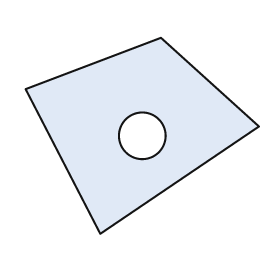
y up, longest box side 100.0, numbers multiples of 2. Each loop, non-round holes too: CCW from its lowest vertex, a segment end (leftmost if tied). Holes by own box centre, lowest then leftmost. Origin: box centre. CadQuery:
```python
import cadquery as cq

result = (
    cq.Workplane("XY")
    .moveTo(-18.0, -42.0)
    .lineTo(50.0, 4.0)
    .lineTo(8.0, 42.0)
    .lineTo(-50.0, 20.0)
    .close()
    .moveTo(0.0, 0.0)
    .circle(10.0)
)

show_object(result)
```